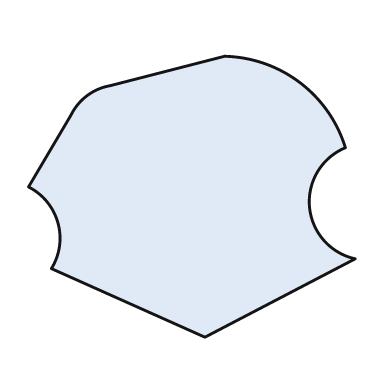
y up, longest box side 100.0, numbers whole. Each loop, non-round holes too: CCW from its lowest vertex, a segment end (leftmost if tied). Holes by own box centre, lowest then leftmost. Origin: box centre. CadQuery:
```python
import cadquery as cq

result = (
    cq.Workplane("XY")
    .moveTo(4.0, -43.0)
    .lineTo(50.0, -19.0)
    .threePointArc((36.0, -3.0), (47.0, 15.0))
    .threePointArc((33.0, 35.0), (10.0, 43.0))
    .lineTo(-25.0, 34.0)
    .threePointArc((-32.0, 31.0), (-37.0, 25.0))
    .lineTo(-50.0, 3.0)
    .threePointArc((-41.0, -8.0), (-43.0, -22.0))
    .close()
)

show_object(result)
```